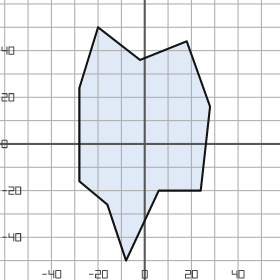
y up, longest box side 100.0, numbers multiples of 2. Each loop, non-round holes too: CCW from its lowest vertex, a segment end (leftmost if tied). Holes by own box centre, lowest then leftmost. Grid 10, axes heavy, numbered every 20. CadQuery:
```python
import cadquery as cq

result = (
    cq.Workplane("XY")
    .moveTo(-8.0, -50.0)
    .lineTo(6.0, -20.0)
    .lineTo(24.0, -20.0)
    .lineTo(28.0, 16.0)
    .lineTo(18.0, 44.0)
    .lineTo(-2.0, 36.0)
    .lineTo(-20.0, 50.0)
    .lineTo(-28.0, 24.0)
    .lineTo(-28.0, -16.0)
    .lineTo(-16.0, -26.0)
    .close()
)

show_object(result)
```